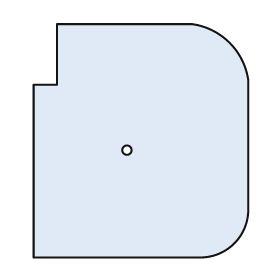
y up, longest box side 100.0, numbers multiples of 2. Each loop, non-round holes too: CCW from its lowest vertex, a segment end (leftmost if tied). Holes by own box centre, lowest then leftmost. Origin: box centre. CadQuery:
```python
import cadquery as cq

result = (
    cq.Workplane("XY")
    .moveTo(-46.0, -50.0)
    .lineTo(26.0, -50.0)
    .threePointArc((40.0, -44.0), (46.0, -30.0))
    .lineTo(46.0, 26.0)
    .threePointArc((38.0, 42.0), (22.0, 50.0))
    .lineTo(-36.0, 50.0)
    .lineTo(-36.0, 24.0)
    .lineTo(-46.0, 24.0)
    .close()
    .moveTo(-6.0, -4.0)
    .circle(2.0)
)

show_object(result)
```